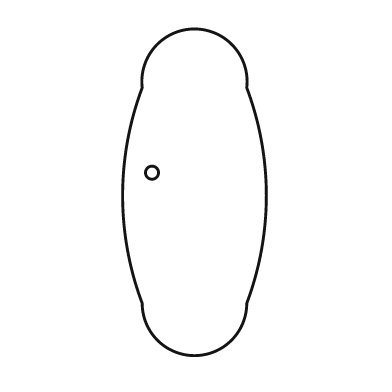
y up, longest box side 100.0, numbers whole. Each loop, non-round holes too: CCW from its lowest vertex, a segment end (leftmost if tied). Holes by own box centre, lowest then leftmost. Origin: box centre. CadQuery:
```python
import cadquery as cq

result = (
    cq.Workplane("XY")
    .moveTo(-16.0, -34.0)
    .threePointArc((0.0, -50.0), (16.0, -34.0))
    .threePointArc((22.0, -1.0), (16.0, 32.0))
    .threePointArc((0.0, 50.0), (-16.0, 32.0))
    .threePointArc((-22.0, -1.0), (-16.0, -34.0))
    .close()
    .moveTo(-13.0, 6.0)
    .circle(2.0)
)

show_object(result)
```